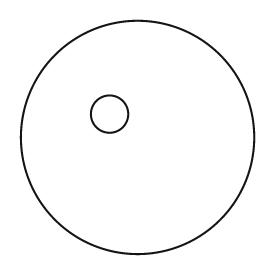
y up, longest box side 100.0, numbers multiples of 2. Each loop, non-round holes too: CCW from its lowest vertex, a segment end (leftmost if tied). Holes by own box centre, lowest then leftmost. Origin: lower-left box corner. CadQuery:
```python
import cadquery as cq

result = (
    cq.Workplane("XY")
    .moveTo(50.0, 50.0)
    .circle(50.0)
    .moveTo(38.0, 60.0)
    .circle(8.0)
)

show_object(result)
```